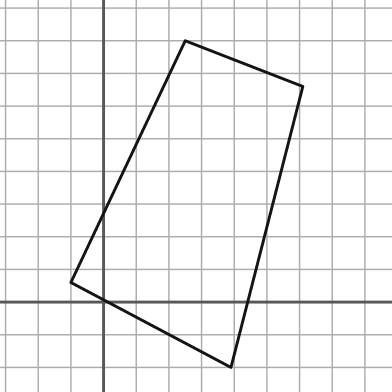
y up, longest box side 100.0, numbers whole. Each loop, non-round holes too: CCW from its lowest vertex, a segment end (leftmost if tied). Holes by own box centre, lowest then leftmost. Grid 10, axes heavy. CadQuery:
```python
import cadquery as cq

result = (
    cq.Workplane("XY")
    .moveTo(39.0, -20.0)
    .lineTo(61.0, 66.0)
    .lineTo(25.0, 80.0)
    .lineTo(-10.0, 6.0)
    .close()
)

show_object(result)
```